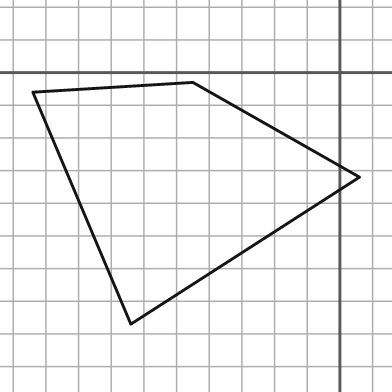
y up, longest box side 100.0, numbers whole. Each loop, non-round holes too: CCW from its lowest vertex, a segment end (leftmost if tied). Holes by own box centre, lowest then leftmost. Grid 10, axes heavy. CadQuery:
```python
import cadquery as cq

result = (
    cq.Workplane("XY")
    .moveTo(-64.0, -77.0)
    .lineTo(6.0, -32.0)
    .lineTo(-45.0, -3.0)
    .lineTo(-94.0, -6.0)
    .close()
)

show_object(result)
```